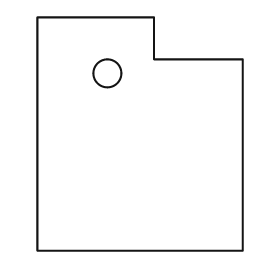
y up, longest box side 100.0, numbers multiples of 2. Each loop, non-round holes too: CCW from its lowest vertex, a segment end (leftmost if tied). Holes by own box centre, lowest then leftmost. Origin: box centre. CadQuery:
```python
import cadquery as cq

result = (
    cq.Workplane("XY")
    .moveTo(-44.0, -50.0)
    .lineTo(44.0, -50.0)
    .lineTo(44.0, 32.0)
    .lineTo(6.0, 32.0)
    .lineTo(6.0, 50.0)
    .lineTo(-44.0, 50.0)
    .close()
    .moveTo(-14.0, 26.0)
    .circle(6.0)
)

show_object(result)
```